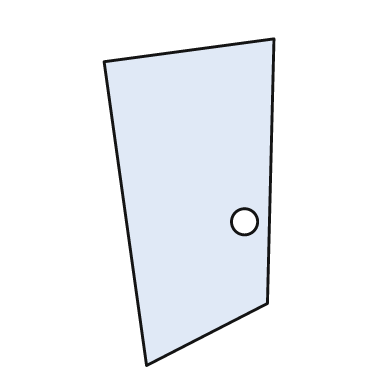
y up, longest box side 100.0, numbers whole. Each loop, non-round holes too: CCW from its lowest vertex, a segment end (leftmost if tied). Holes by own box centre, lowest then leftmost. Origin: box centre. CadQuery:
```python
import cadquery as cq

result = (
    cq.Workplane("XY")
    .moveTo(-13.0, -50.0)
    .lineTo(24.0, -31.0)
    .lineTo(26.0, 50.0)
    .lineTo(-26.0, 43.0)
    .close()
    .moveTo(17.0, -6.0)
    .circle(4.0)
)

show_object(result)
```